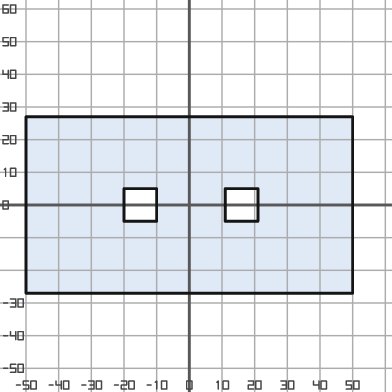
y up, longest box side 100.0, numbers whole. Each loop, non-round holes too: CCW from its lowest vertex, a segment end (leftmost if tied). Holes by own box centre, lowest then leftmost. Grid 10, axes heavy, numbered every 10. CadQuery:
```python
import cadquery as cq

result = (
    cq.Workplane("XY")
    .moveTo(-50.0, -27.0)
    .lineTo(50.0, -27.0)
    .lineTo(50.0, 27.0)
    .lineTo(-50.0, 27.0)
    .close()
    .moveTo(-20.0, -5.0)
    .lineTo(-10.0, -5.0)
    .lineTo(-10.0, 5.0)
    .lineTo(-20.0, 5.0)
    .close()
    .moveTo(11.0, -5.0)
    .lineTo(21.0, -5.0)
    .lineTo(21.0, 5.0)
    .lineTo(11.0, 5.0)
    .close()
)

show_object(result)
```